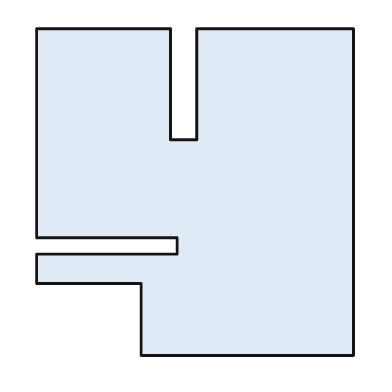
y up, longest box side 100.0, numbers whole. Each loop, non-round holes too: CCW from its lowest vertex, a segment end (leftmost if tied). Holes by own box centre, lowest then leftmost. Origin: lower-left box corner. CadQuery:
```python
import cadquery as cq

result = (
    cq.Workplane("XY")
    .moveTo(32.0, 0.0)
    .lineTo(97.0, 0.0)
    .lineTo(97.0, 100.0)
    .lineTo(49.0, 100.0)
    .lineTo(49.0, 66.0)
    .lineTo(41.0, 66.0)
    .lineTo(41.0, 100.0)
    .lineTo(0.0, 100.0)
    .lineTo(0.0, 36.0)
    .lineTo(43.0, 36.0)
    .lineTo(43.0, 31.0)
    .lineTo(0.0, 31.0)
    .lineTo(0.0, 22.0)
    .lineTo(32.0, 22.0)
    .close()
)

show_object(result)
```